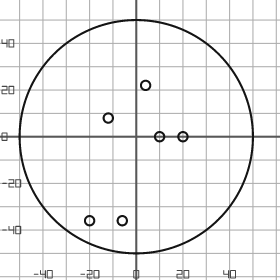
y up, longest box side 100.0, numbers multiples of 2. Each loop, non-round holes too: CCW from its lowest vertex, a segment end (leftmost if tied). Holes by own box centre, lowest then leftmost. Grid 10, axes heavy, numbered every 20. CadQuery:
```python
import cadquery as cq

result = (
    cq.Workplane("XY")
    .moveTo(0.0, 0.0)
    .circle(50.0)
    .moveTo(-20.0, -36.0)
    .circle(2.0)
    .moveTo(-6.0, -36.0)
    .circle(2.0)
    .moveTo(10.0, 0.0)
    .circle(2.0)
    .moveTo(20.0, 0.0)
    .circle(2.0)
    .moveTo(-12.0, 8.0)
    .circle(2.0)
    .moveTo(4.0, 22.0)
    .circle(2.0)
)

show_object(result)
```